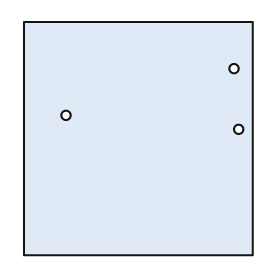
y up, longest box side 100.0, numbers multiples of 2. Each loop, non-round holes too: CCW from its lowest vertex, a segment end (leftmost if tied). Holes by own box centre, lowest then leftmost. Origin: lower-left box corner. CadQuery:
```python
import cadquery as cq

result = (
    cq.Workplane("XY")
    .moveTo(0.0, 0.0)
    .lineTo(98.0, 0.0)
    .lineTo(98.0, 100.0)
    .lineTo(0.0, 100.0)
    .close()
    .moveTo(92.0, 54.0)
    .circle(2.0)
    .moveTo(18.0, 60.0)
    .circle(2.0)
    .moveTo(90.0, 80.0)
    .circle(2.0)
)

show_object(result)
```